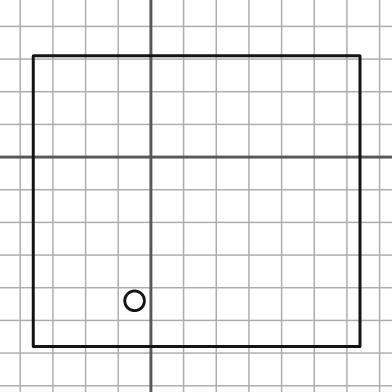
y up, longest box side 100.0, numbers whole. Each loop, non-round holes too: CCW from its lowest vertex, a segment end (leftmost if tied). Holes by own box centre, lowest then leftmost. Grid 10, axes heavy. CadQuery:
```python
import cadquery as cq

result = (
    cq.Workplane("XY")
    .moveTo(-36.0, -58.0)
    .lineTo(64.0, -58.0)
    .lineTo(64.0, 31.0)
    .lineTo(-36.0, 31.0)
    .close()
    .moveTo(-5.0, -44.0)
    .circle(3.0)
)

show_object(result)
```